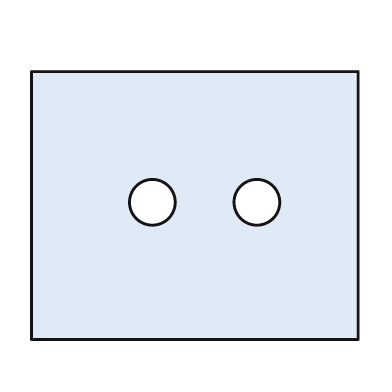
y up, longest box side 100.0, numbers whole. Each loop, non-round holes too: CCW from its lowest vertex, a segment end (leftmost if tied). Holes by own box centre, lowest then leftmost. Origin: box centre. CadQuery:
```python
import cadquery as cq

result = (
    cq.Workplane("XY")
    .moveTo(-50.0, -41.0)
    .lineTo(50.0, -41.0)
    .lineTo(50.0, 41.0)
    .lineTo(-50.0, 41.0)
    .close()
    .moveTo(-13.0, 1.0)
    .circle(7.0)
    .moveTo(19.0, 1.0)
    .circle(7.0)
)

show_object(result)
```